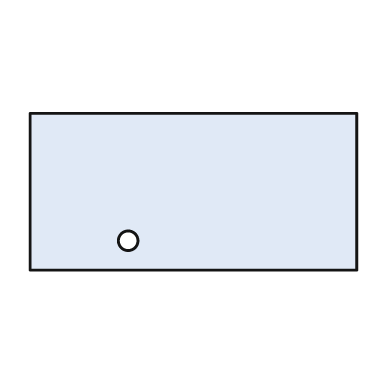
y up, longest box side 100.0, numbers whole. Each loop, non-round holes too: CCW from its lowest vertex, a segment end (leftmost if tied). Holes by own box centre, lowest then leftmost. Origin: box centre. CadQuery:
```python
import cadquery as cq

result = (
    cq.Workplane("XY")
    .moveTo(-50.0, -24.0)
    .lineTo(50.0, -24.0)
    .lineTo(50.0, 24.0)
    .lineTo(-50.0, 24.0)
    .close()
    .moveTo(-20.0, -15.0)
    .circle(3.0)
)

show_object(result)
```